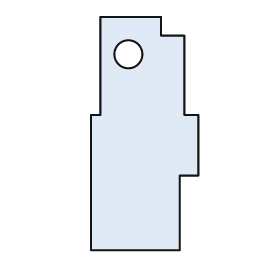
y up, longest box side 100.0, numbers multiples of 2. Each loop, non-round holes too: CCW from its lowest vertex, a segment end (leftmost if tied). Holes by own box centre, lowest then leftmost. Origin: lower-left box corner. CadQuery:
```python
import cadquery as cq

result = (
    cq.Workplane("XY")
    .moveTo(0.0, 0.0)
    .lineTo(38.0, 0.0)
    .lineTo(38.0, 32.0)
    .lineTo(46.0, 32.0)
    .lineTo(46.0, 58.0)
    .lineTo(40.0, 58.0)
    .lineTo(40.0, 92.0)
    .lineTo(30.0, 92.0)
    .lineTo(30.0, 100.0)
    .lineTo(4.0, 100.0)
    .lineTo(4.0, 58.0)
    .lineTo(0.0, 58.0)
    .close()
    .moveTo(16.0, 84.0)
    .circle(6.0)
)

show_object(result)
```